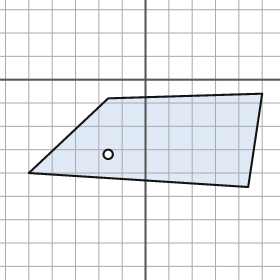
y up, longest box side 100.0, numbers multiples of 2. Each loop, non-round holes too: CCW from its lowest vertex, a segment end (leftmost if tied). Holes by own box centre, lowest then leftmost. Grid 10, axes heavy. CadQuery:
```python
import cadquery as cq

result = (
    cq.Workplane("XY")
    .moveTo(44.0, -46.0)
    .lineTo(50.0, -6.0)
    .lineTo(-16.0, -8.0)
    .lineTo(-50.0, -40.0)
    .close()
    .moveTo(-16.0, -32.0)
    .circle(2.0)
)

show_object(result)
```